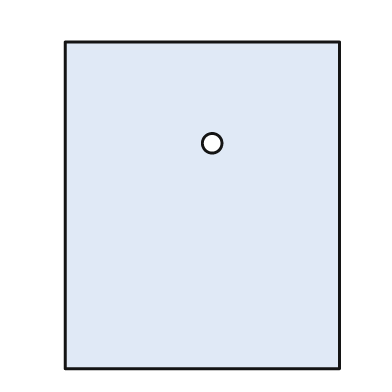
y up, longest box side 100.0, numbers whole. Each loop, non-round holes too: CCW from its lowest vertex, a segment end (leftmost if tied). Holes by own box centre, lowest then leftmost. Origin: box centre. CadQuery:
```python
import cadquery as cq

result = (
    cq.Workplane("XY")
    .moveTo(-42.0, -50.0)
    .lineTo(42.0, -50.0)
    .lineTo(42.0, 50.0)
    .lineTo(-42.0, 50.0)
    .close()
    .moveTo(3.0, 19.0)
    .circle(3.0)
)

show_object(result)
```